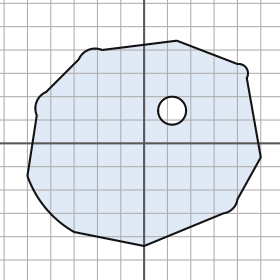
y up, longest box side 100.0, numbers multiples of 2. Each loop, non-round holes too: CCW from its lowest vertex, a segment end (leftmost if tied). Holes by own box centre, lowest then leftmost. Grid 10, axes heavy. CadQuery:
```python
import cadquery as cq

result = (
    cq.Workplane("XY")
    .moveTo(0.0, -44.0)
    .lineTo(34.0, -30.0)
    .threePointArc((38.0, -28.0), (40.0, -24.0))
    .lineTo(50.0, -6.0)
    .lineTo(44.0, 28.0)
    .threePointArc((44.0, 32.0), (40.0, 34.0))
    .lineTo(14.0, 44.0)
    .lineTo(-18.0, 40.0)
    .threePointArc((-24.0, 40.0), (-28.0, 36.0))
    .lineTo(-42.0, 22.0)
    .threePointArc((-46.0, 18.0), (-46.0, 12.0))
    .lineTo(-50.0, -14.0)
    .threePointArc((-42.0, -28.0), (-30.0, -38.0))
    .close()
    .moveTo(12.0, 14.0)
    .circle(6.0)
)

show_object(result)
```